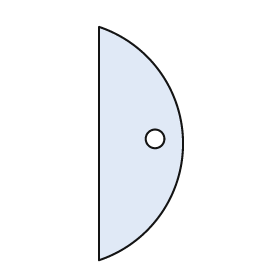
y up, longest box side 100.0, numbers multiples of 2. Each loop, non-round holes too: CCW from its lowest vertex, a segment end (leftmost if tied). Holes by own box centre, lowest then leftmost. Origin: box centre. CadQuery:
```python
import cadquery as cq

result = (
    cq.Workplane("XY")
    .moveTo(-18.0, -50.0)
    .threePointArc((18.0, 0.0), (-18.0, 50.0))
    .close()
    .moveTo(6.0, 2.0)
    .circle(4.0)
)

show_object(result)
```